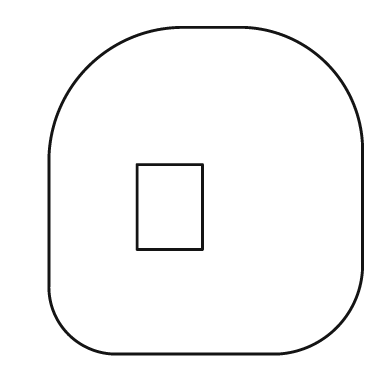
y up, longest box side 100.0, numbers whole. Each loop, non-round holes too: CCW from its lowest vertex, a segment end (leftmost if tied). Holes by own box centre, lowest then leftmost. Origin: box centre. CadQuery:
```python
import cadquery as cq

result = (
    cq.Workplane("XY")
    .moveTo(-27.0, -50.0)
    .lineTo(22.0, -50.0)
    .threePointArc((40.0, -42.0), (48.0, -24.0))
    .lineTo(48.0, 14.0)
    .threePointArc((37.0, 39.0), (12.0, 50.0))
    .lineTo(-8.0, 50.0)
    .threePointArc((-36.0, 38.0), (-48.0, 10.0))
    .lineTo(-48.0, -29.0)
    .threePointArc((-42.0, -44.0), (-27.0, -50.0))
    .close()
    .moveTo(-21.0, -18.0)
    .lineTo(-1.0, -18.0)
    .lineTo(-1.0, 8.0)
    .lineTo(-21.0, 8.0)
    .close()
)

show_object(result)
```